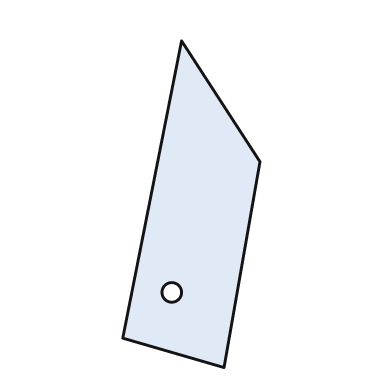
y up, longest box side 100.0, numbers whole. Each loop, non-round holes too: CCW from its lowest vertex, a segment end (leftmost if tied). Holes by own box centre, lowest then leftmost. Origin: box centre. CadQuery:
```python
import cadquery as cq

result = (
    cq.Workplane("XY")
    .moveTo(10.0, -50.0)
    .lineTo(21.0, 13.0)
    .lineTo(-3.0, 50.0)
    .lineTo(-21.0, -41.0)
    .close()
    .moveTo(-6.0, -27.0)
    .circle(3.0)
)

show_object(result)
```